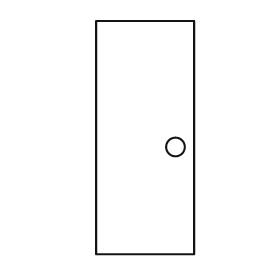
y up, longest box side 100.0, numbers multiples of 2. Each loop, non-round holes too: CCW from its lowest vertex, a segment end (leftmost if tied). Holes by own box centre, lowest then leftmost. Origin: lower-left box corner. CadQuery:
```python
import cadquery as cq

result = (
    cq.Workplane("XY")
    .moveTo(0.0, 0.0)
    .lineTo(42.0, 0.0)
    .lineTo(42.0, 100.0)
    .lineTo(0.0, 100.0)
    .close()
    .moveTo(34.0, 46.0)
    .circle(4.0)
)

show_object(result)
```